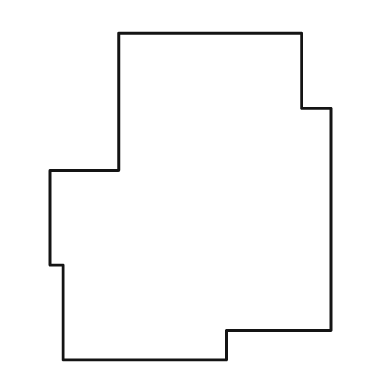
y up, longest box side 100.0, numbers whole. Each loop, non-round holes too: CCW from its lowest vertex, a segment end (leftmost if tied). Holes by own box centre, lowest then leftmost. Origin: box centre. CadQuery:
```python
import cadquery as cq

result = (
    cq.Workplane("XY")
    .moveTo(-39.0, -50.0)
    .lineTo(11.0, -50.0)
    .lineTo(11.0, -41.0)
    .lineTo(43.0, -41.0)
    .lineTo(43.0, 27.0)
    .lineTo(34.0, 27.0)
    .lineTo(34.0, 50.0)
    .lineTo(-22.0, 50.0)
    .lineTo(-22.0, 8.0)
    .lineTo(-43.0, 8.0)
    .lineTo(-43.0, -21.0)
    .lineTo(-39.0, -21.0)
    .close()
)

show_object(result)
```